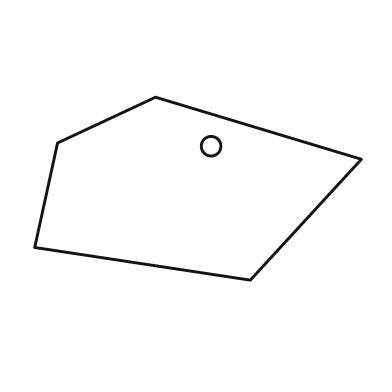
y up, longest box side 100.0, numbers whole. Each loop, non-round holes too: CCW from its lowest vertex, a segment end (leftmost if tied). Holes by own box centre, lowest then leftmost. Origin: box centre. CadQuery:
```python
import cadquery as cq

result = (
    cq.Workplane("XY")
    .moveTo(16.0, -28.0)
    .lineTo(50.0, 9.0)
    .lineTo(-13.0, 28.0)
    .lineTo(-43.0, 14.0)
    .lineTo(-50.0, -18.0)
    .close()
    .moveTo(4.0, 13.0)
    .circle(3.0)
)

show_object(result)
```